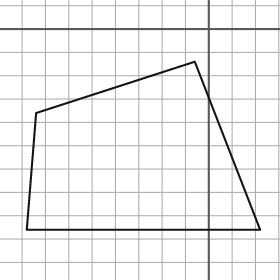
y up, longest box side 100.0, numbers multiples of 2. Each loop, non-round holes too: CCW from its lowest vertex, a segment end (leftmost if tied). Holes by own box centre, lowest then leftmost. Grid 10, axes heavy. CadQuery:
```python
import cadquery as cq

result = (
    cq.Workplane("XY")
    .moveTo(-78.0, -86.0)
    .lineTo(22.0, -86.0)
    .lineTo(-6.0, -14.0)
    .lineTo(-74.0, -36.0)
    .close()
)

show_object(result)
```